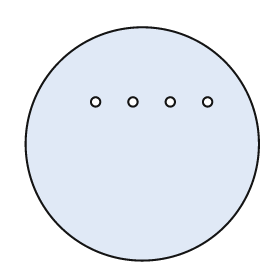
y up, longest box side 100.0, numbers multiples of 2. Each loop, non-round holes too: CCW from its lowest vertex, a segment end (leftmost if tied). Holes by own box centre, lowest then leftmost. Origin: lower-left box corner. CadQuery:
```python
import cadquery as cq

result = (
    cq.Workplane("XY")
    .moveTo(50.0, 50.0)
    .circle(50.0)
    .moveTo(30.0, 68.0)
    .circle(2.0)
    .moveTo(46.0, 68.0)
    .circle(2.0)
    .moveTo(62.0, 68.0)
    .circle(2.0)
    .moveTo(78.0, 68.0)
    .circle(2.0)
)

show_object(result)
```